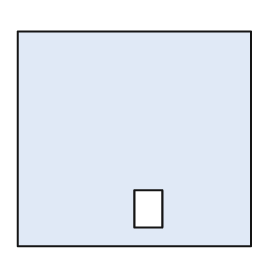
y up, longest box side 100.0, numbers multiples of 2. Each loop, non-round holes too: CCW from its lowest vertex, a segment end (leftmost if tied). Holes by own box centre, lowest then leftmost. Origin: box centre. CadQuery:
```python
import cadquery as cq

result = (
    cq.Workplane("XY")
    .moveTo(-50.0, -46.0)
    .lineTo(50.0, -46.0)
    .lineTo(50.0, 46.0)
    .lineTo(-50.0, 46.0)
    .close()
    .moveTo(0.0, -38.0)
    .lineTo(12.0, -38.0)
    .lineTo(12.0, -22.0)
    .lineTo(0.0, -22.0)
    .close()
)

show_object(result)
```